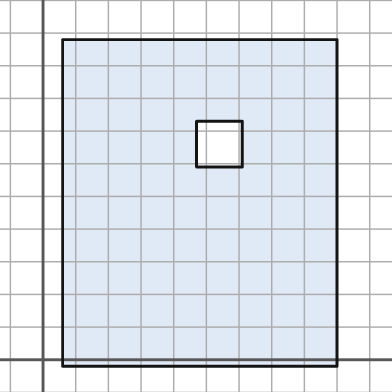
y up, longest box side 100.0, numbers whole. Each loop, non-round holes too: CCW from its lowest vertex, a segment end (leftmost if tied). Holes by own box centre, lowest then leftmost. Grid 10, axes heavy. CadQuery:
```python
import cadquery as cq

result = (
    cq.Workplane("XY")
    .moveTo(6.0, -2.0)
    .lineTo(90.0, -2.0)
    .lineTo(90.0, 98.0)
    .lineTo(6.0, 98.0)
    .close()
    .moveTo(47.0, 59.0)
    .lineTo(61.0, 59.0)
    .lineTo(61.0, 73.0)
    .lineTo(47.0, 73.0)
    .close()
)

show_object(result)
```